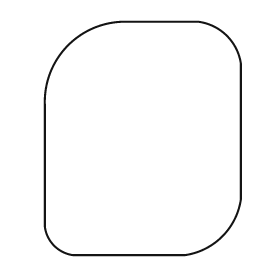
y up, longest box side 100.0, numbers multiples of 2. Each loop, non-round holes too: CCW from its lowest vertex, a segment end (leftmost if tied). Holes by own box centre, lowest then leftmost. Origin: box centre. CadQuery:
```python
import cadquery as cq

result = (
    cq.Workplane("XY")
    .moveTo(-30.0, -50.0)
    .lineTo(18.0, -50.0)
    .threePointArc((34.0, -42.0), (42.0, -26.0))
    .lineTo(42.0, 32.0)
    .threePointArc((36.0, 44.0), (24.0, 50.0))
    .lineTo(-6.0, 50.0)
    .threePointArc((-32.0, 40.0), (-42.0, 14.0))
    .lineTo(-42.0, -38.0)
    .threePointArc((-38.0, -46.0), (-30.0, -50.0))
    .close()
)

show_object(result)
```